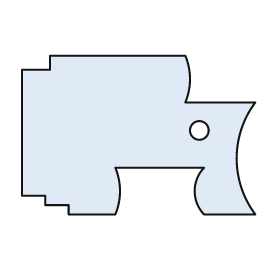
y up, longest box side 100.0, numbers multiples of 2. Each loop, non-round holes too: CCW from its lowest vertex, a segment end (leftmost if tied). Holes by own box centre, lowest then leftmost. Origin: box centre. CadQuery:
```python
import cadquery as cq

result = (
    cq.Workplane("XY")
    .moveTo(-30.0, -34.0)
    .lineTo(-10.0, -34.0)
    .threePointArc((-8.0, -24.0), (-10.0, -14.0))
    .lineTo(28.0, -14.0)
    .threePointArc((24.0, -24.0), (28.0, -34.0))
    .lineTo(50.0, -34.0)
    .threePointArc((42.0, -10.0), (50.0, 14.0))
    .lineTo(20.0, 14.0)
    .threePointArc((22.0, 24.0), (20.0, 34.0))
    .lineTo(-38.0, 34.0)
    .lineTo(-38.0, 28.0)
    .lineTo(-50.0, 28.0)
    .lineTo(-50.0, -26.0)
    .lineTo(-40.0, -26.0)
    .lineTo(-40.0, -30.0)
    .lineTo(-30.0, -30.0)
    .close()
    .moveTo(26.0, 2.0)
    .circle(4.0)
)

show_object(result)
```